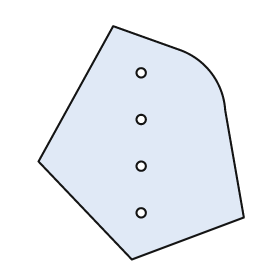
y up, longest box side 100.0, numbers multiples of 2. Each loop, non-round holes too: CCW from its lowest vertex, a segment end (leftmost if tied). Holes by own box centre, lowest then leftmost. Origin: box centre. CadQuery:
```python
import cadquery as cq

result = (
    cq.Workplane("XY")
    .moveTo(-4.0, -50.0)
    .lineTo(44.0, -32.0)
    .lineTo(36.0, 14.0)
    .threePointArc((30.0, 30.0), (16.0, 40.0))
    .lineTo(-12.0, 50.0)
    .lineTo(-44.0, -8.0)
    .close()
    .moveTo(0.0, -30.0)
    .circle(2.0)
    .moveTo(0.0, -10.0)
    .circle(2.0)
    .moveTo(0.0, 10.0)
    .circle(2.0)
    .moveTo(0.0, 30.0)
    .circle(2.0)
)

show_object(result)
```